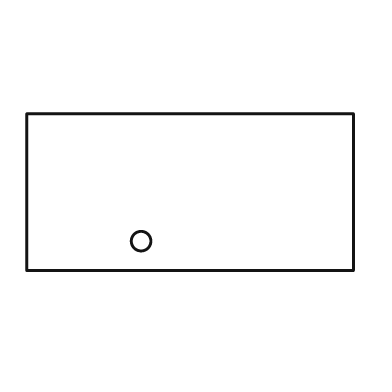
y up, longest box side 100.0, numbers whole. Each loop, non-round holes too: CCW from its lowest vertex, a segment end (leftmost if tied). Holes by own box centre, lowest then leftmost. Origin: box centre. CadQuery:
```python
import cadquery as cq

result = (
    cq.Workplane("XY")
    .moveTo(-50.0, -24.0)
    .lineTo(50.0, -24.0)
    .lineTo(50.0, 24.0)
    .lineTo(-50.0, 24.0)
    .close()
    .moveTo(-15.0, -15.0)
    .circle(3.0)
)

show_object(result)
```